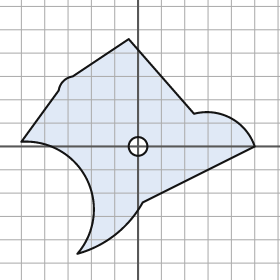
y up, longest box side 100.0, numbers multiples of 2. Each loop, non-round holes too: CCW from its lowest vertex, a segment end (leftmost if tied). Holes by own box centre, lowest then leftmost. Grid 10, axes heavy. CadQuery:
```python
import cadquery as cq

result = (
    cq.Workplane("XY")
    .moveTo(-26.0, -46.0)
    .threePointArc((-10.0, -38.0), (2.0, -24.0))
    .lineTo(50.0, 0.0)
    .threePointArc((40.0, 12.0), (24.0, 14.0))
    .lineTo(-4.0, 46.0)
    .lineTo(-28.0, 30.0)
    .threePointArc((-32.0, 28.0), (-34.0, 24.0))
    .lineTo(-50.0, 2.0)
    .threePointArc((-22.0, -14.0), (-26.0, -46.0))
    .close()
    .moveTo(0.0, 0.0)
    .circle(4.0)
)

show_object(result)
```